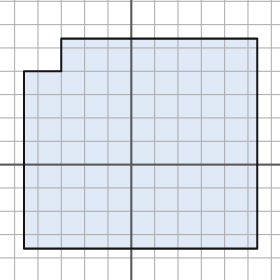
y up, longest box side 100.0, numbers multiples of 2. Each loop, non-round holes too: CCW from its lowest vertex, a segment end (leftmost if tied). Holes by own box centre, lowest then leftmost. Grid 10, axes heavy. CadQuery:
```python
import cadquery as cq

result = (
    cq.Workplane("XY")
    .moveTo(-46.0, -36.0)
    .lineTo(54.0, -36.0)
    .lineTo(54.0, 54.0)
    .lineTo(-30.0, 54.0)
    .lineTo(-30.0, 40.0)
    .lineTo(-46.0, 40.0)
    .close()
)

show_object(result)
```